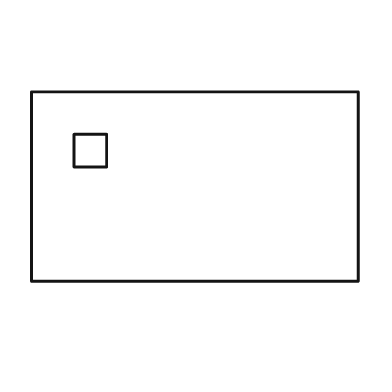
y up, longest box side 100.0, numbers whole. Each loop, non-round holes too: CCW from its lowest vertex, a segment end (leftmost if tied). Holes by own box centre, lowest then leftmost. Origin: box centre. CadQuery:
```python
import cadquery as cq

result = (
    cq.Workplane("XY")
    .moveTo(-50.0, -29.0)
    .lineTo(50.0, -29.0)
    .lineTo(50.0, 29.0)
    .lineTo(-50.0, 29.0)
    .close()
    .moveTo(-37.0, 6.0)
    .lineTo(-27.0, 6.0)
    .lineTo(-27.0, 16.0)
    .lineTo(-37.0, 16.0)
    .close()
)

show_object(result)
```